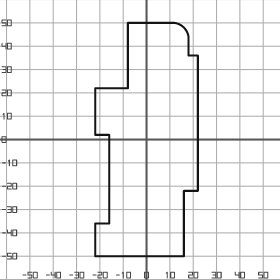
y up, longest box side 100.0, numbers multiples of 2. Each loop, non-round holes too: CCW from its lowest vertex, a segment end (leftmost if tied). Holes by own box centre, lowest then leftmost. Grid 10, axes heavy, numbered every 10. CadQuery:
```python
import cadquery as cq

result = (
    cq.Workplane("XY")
    .moveTo(-22.0, -50.0)
    .lineTo(16.0, -50.0)
    .lineTo(16.0, -22.0)
    .lineTo(22.0, -22.0)
    .lineTo(22.0, 36.0)
    .lineTo(18.0, 36.0)
    .lineTo(18.0, 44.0)
    .threePointArc((16.0, 48.0), (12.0, 50.0))
    .lineTo(-8.0, 50.0)
    .lineTo(-8.0, 22.0)
    .lineTo(-22.0, 22.0)
    .lineTo(-22.0, 2.0)
    .lineTo(-16.0, 2.0)
    .lineTo(-16.0, -36.0)
    .lineTo(-22.0, -36.0)
    .close()
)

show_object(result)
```